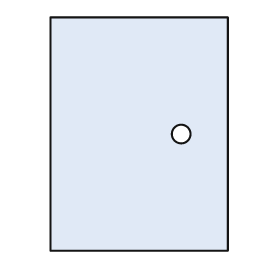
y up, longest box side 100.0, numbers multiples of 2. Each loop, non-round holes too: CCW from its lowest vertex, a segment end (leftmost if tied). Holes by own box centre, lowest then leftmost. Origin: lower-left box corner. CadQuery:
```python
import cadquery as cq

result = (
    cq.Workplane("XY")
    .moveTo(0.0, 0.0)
    .lineTo(76.0, 0.0)
    .lineTo(76.0, 100.0)
    .lineTo(0.0, 100.0)
    .close()
    .moveTo(56.0, 50.0)
    .circle(4.0)
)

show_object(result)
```